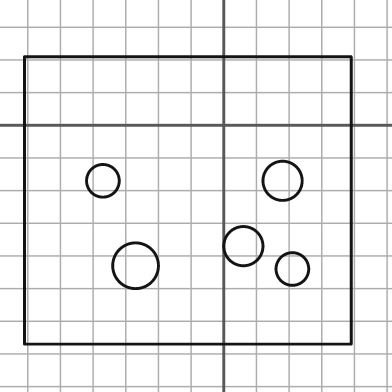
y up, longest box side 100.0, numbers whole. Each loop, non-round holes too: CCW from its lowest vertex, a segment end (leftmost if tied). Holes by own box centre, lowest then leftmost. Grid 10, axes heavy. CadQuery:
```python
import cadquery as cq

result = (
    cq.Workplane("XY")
    .moveTo(-61.0, -67.0)
    .lineTo(39.0, -67.0)
    .lineTo(39.0, 21.0)
    .lineTo(-61.0, 21.0)
    .close()
    .moveTo(21.0, -44.0)
    .circle(5.0)
    .moveTo(-27.0, -43.0)
    .circle(7.0)
    .moveTo(6.0, -37.0)
    .circle(6.0)
    .moveTo(-37.0, -17.0)
    .circle(5.0)
    .moveTo(18.0, -17.0)
    .circle(6.0)
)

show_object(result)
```